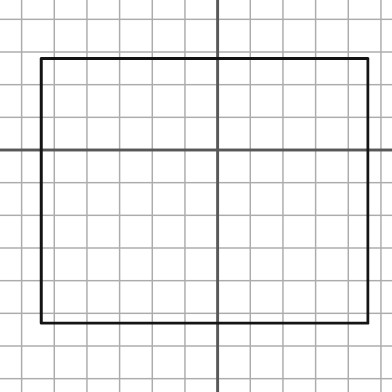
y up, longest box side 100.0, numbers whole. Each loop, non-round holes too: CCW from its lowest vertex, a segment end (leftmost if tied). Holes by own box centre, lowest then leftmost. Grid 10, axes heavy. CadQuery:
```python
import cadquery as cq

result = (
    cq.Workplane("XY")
    .moveTo(-54.0, -53.0)
    .lineTo(46.0, -53.0)
    .lineTo(46.0, 28.0)
    .lineTo(-54.0, 28.0)
    .close()
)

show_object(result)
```